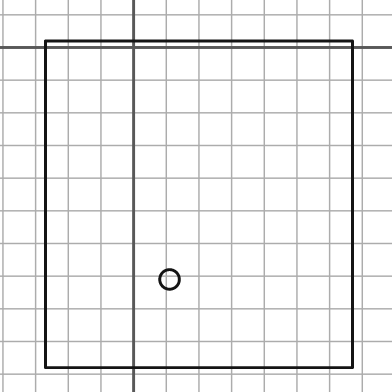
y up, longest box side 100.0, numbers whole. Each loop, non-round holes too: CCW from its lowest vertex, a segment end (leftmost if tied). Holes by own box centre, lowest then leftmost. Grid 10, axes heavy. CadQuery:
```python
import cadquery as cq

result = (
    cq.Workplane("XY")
    .moveTo(-27.0, -98.0)
    .lineTo(67.0, -98.0)
    .lineTo(67.0, 2.0)
    .lineTo(-27.0, 2.0)
    .close()
    .moveTo(11.0, -71.0)
    .circle(3.0)
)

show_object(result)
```